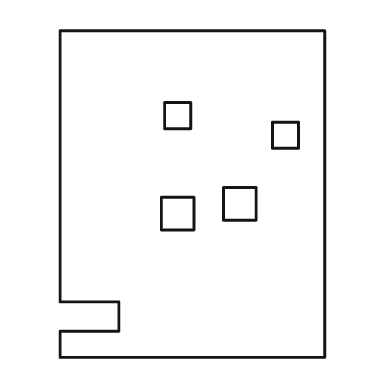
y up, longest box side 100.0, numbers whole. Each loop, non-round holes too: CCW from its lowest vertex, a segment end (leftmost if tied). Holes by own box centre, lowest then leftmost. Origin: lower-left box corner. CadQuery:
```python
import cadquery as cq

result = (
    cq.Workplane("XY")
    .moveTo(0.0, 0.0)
    .lineTo(81.0, 0.0)
    .lineTo(81.0, 100.0)
    .lineTo(0.0, 100.0)
    .lineTo(0.0, 17.0)
    .lineTo(18.0, 17.0)
    .lineTo(18.0, 8.0)
    .lineTo(0.0, 8.0)
    .close()
    .moveTo(31.0, 39.0)
    .lineTo(41.0, 39.0)
    .lineTo(41.0, 49.0)
    .lineTo(31.0, 49.0)
    .close()
    .moveTo(50.0, 42.0)
    .lineTo(60.0, 42.0)
    .lineTo(60.0, 52.0)
    .lineTo(50.0, 52.0)
    .close()
    .moveTo(65.0, 64.0)
    .lineTo(73.0, 64.0)
    .lineTo(73.0, 72.0)
    .lineTo(65.0, 72.0)
    .close()
    .moveTo(32.0, 70.0)
    .lineTo(40.0, 70.0)
    .lineTo(40.0, 78.0)
    .lineTo(32.0, 78.0)
    .close()
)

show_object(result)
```